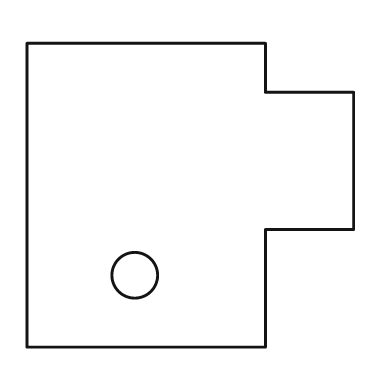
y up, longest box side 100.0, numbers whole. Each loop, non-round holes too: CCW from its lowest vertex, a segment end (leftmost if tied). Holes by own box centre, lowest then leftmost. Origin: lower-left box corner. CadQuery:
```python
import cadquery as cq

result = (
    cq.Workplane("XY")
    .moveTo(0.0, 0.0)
    .lineTo(73.0, 0.0)
    .lineTo(73.0, 36.0)
    .lineTo(100.0, 36.0)
    .lineTo(100.0, 78.0)
    .lineTo(73.0, 78.0)
    .lineTo(73.0, 93.0)
    .lineTo(0.0, 93.0)
    .close()
    .moveTo(33.0, 22.0)
    .circle(7.0)
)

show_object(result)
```